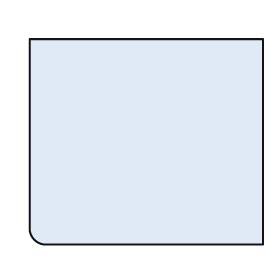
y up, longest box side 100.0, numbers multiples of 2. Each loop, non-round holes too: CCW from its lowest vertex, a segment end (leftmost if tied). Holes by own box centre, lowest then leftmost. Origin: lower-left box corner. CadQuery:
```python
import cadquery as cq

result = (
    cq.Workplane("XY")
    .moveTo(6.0, 0.0)
    .lineTo(100.0, 0.0)
    .lineTo(100.0, 88.0)
    .lineTo(0.0, 88.0)
    .lineTo(0.0, 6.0)
    .threePointArc((2.0, 2.0), (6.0, 0.0))
    .close()
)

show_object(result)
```